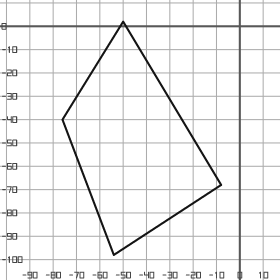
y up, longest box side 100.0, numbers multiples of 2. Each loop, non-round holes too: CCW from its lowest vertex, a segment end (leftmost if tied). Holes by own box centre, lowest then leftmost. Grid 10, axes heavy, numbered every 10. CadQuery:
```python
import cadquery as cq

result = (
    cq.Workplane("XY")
    .moveTo(-54.0, -98.0)
    .lineTo(-8.0, -68.0)
    .lineTo(-50.0, 2.0)
    .lineTo(-76.0, -40.0)
    .close()
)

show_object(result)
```